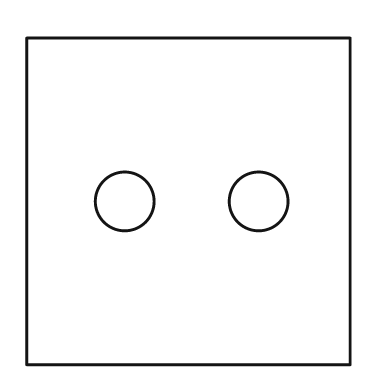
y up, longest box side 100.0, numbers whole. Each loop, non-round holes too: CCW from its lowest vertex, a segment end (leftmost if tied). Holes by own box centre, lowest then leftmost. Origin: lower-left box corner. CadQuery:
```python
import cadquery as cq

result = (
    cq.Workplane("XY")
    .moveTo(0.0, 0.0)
    .lineTo(99.0, 0.0)
    .lineTo(99.0, 100.0)
    .lineTo(0.0, 100.0)
    .close()
    .moveTo(30.0, 50.0)
    .circle(9.0)
    .moveTo(71.0, 50.0)
    .circle(9.0)
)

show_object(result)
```